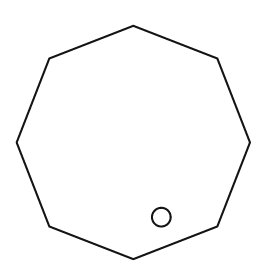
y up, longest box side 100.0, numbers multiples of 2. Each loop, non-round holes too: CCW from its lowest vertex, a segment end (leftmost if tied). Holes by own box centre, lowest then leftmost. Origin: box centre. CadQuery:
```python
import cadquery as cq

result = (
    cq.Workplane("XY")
    .moveTo(0.0, -50.0)
    .lineTo(36.0, -36.0)
    .lineTo(50.0, 0.0)
    .lineTo(36.0, 36.0)
    .lineTo(0.0, 50.0)
    .lineTo(-36.0, 36.0)
    .lineTo(-50.0, 0.0)
    .lineTo(-36.0, -36.0)
    .close()
    .moveTo(12.0, -32.0)
    .circle(4.0)
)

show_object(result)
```